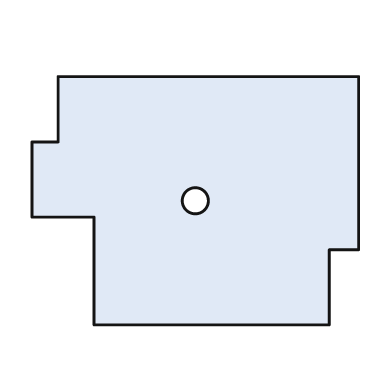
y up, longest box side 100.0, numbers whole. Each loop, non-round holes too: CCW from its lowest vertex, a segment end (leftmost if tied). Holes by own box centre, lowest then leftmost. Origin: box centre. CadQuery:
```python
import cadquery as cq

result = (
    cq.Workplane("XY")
    .moveTo(-31.0, -38.0)
    .lineTo(41.0, -38.0)
    .lineTo(41.0, -15.0)
    .lineTo(50.0, -15.0)
    .lineTo(50.0, 38.0)
    .lineTo(-42.0, 38.0)
    .lineTo(-42.0, 18.0)
    .lineTo(-50.0, 18.0)
    .lineTo(-50.0, -5.0)
    .lineTo(-31.0, -5.0)
    .close()
    .moveTo(0.0, 0.0)
    .circle(4.0)
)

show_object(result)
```